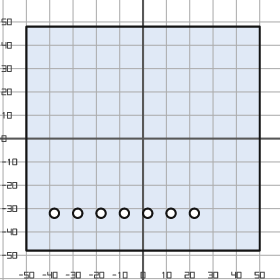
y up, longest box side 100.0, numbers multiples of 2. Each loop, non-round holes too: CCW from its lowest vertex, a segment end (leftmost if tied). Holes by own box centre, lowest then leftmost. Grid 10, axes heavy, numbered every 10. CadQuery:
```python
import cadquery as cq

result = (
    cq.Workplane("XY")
    .moveTo(-50.0, -48.0)
    .lineTo(50.0, -48.0)
    .lineTo(50.0, 48.0)
    .lineTo(-50.0, 48.0)
    .close()
    .moveTo(-38.0, -32.0)
    .circle(2.0)
    .moveTo(-28.0, -32.0)
    .circle(2.0)
    .moveTo(-18.0, -32.0)
    .circle(2.0)
    .moveTo(-8.0, -32.0)
    .circle(2.0)
    .moveTo(2.0, -32.0)
    .circle(2.0)
    .moveTo(12.0, -32.0)
    .circle(2.0)
    .moveTo(22.0, -32.0)
    .circle(2.0)
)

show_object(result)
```